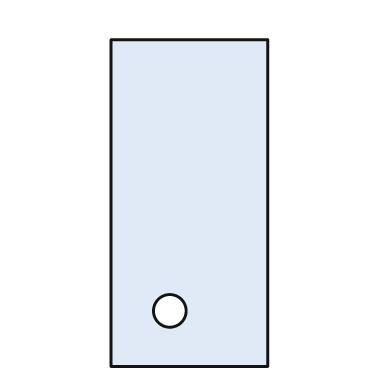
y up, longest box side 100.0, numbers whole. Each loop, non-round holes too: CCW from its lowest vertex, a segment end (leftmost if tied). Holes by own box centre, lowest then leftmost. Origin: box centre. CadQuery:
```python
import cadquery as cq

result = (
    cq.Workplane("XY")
    .moveTo(-24.0, -50.0)
    .lineTo(24.0, -50.0)
    .lineTo(24.0, 50.0)
    .lineTo(-24.0, 50.0)
    .close()
    .moveTo(-6.0, -33.0)
    .circle(5.0)
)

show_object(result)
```